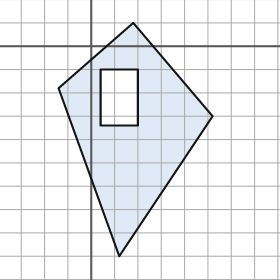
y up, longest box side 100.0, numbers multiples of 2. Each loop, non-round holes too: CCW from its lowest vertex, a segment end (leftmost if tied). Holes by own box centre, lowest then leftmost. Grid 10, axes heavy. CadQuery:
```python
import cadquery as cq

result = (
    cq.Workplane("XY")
    .moveTo(12.0, -90.0)
    .lineTo(52.0, -30.0)
    .lineTo(18.0, 10.0)
    .lineTo(-14.0, -18.0)
    .close()
    .moveTo(4.0, -34.0)
    .lineTo(20.0, -34.0)
    .lineTo(20.0, -10.0)
    .lineTo(4.0, -10.0)
    .close()
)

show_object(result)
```